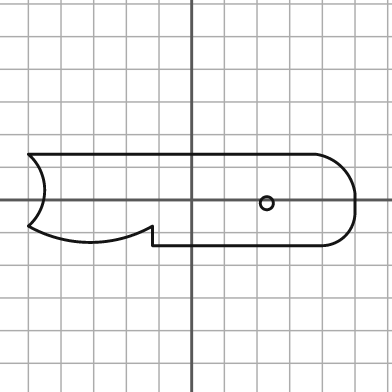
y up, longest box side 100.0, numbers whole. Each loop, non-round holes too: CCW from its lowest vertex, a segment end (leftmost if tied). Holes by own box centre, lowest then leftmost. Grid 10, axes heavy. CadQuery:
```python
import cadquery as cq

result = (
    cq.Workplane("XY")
    .moveTo(-12.0, -14.0)
    .lineTo(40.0, -14.0)
    .threePointArc((47.0, -11.0), (50.0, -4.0))
    .lineTo(50.0, 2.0)
    .threePointArc((46.0, 10.0), (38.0, 14.0))
    .lineTo(-50.0, 14.0)
    .threePointArc((-45.0, 3.0), (-50.0, -8.0))
    .threePointArc((-31.0, -13.0), (-12.0, -8.0))
    .close()
    .moveTo(23.0, -1.0)
    .circle(2.0)
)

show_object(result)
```